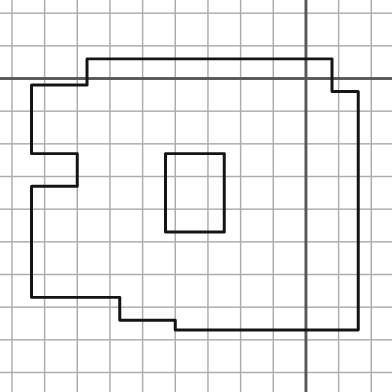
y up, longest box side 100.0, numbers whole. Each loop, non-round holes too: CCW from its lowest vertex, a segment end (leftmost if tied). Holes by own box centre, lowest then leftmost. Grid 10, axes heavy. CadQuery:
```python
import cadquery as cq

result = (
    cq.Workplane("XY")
    .moveTo(-40.0, -77.0)
    .lineTo(16.0, -77.0)
    .lineTo(16.0, -4.0)
    .lineTo(8.0, -4.0)
    .lineTo(8.0, 6.0)
    .lineTo(-67.0, 6.0)
    .lineTo(-67.0, -2.0)
    .lineTo(-84.0, -2.0)
    .lineTo(-84.0, -23.0)
    .lineTo(-70.0, -23.0)
    .lineTo(-70.0, -33.0)
    .lineTo(-84.0, -33.0)
    .lineTo(-84.0, -67.0)
    .lineTo(-57.0, -67.0)
    .lineTo(-57.0, -74.0)
    .lineTo(-40.0, -74.0)
    .close()
    .moveTo(-43.0, -47.0)
    .lineTo(-25.0, -47.0)
    .lineTo(-25.0, -23.0)
    .lineTo(-43.0, -23.0)
    .close()
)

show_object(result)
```